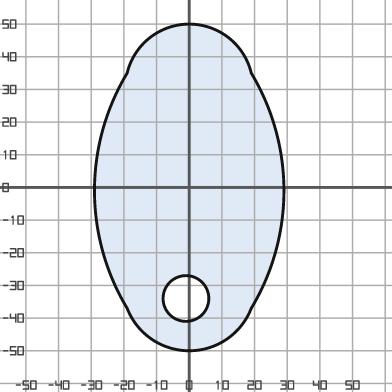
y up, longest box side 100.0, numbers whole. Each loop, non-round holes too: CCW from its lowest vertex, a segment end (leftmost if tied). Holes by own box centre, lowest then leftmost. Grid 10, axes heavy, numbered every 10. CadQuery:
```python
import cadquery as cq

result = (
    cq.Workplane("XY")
    .moveTo(-19.0, -37.0)
    .threePointArc((0.0, -50.0), (19.0, -37.0))
    .threePointArc((29.0, -1.0), (19.0, 35.0))
    .threePointArc((0.0, 50.0), (-19.0, 35.0))
    .threePointArc((-29.0, -1.0), (-19.0, -37.0))
    .close()
    .moveTo(-1.0, -34.0)
    .circle(7.0)
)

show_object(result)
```